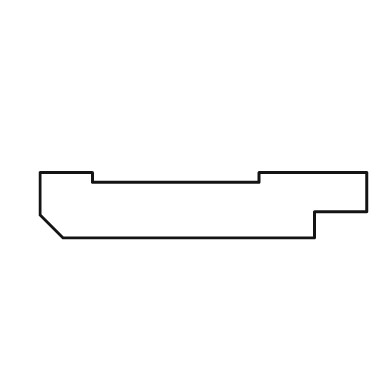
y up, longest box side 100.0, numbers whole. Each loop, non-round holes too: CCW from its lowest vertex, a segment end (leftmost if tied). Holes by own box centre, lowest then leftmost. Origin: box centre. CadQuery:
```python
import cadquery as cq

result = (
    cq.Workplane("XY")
    .moveTo(-43.0, -10.0)
    .lineTo(34.0, -10.0)
    .lineTo(34.0, -2.0)
    .lineTo(50.0, -2.0)
    .lineTo(50.0, 10.0)
    .lineTo(17.0, 10.0)
    .lineTo(17.0, 7.0)
    .lineTo(-34.0, 7.0)
    .lineTo(-34.0, 10.0)
    .lineTo(-50.0, 10.0)
    .lineTo(-50.0, -3.0)
    .close()
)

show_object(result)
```